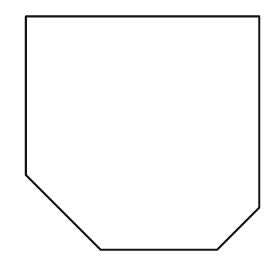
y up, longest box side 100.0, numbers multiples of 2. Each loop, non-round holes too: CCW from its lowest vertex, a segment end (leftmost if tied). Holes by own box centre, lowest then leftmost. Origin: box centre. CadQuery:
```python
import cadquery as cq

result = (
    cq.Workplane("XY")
    .moveTo(-18.0, -50.0)
    .lineTo(32.0, -50.0)
    .lineTo(50.0, -32.0)
    .lineTo(50.0, 50.0)
    .lineTo(-50.0, 50.0)
    .lineTo(-50.0, -18.0)
    .close()
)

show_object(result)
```